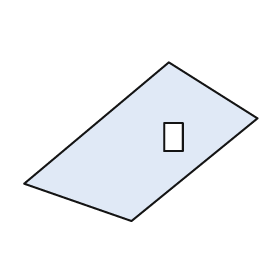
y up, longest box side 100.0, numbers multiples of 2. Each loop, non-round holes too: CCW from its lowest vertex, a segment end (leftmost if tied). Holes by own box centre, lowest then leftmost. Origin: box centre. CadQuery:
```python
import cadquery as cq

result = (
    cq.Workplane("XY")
    .moveTo(-4.0, -34.0)
    .lineTo(50.0, 10.0)
    .lineTo(12.0, 34.0)
    .lineTo(-50.0, -18.0)
    .close()
    .moveTo(10.0, -4.0)
    .lineTo(18.0, -4.0)
    .lineTo(18.0, 8.0)
    .lineTo(10.0, 8.0)
    .close()
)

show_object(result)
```